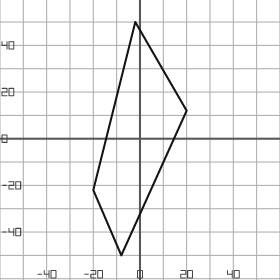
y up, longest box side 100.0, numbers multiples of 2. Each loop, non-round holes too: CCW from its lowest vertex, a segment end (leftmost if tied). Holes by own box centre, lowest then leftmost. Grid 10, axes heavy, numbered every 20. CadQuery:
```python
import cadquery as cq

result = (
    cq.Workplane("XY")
    .moveTo(-8.0, -50.0)
    .lineTo(20.0, 12.0)
    .lineTo(-2.0, 50.0)
    .lineTo(-20.0, -22.0)
    .close()
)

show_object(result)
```